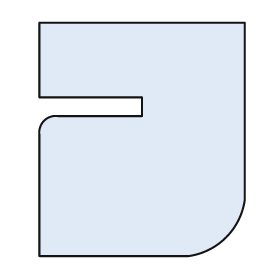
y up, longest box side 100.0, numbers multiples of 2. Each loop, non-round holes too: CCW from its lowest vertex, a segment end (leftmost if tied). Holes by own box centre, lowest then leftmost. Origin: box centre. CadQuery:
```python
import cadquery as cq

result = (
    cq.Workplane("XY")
    .moveTo(-44.0, -50.0)
    .lineTo(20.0, -50.0)
    .threePointArc((36.0, -42.0), (44.0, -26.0))
    .lineTo(44.0, 50.0)
    .lineTo(-44.0, 50.0)
    .lineTo(-44.0, 18.0)
    .lineTo(0.0, 18.0)
    .lineTo(0.0, 10.0)
    .lineTo(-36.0, 10.0)
    .threePointArc((-42.0, 8.0), (-44.0, 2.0))
    .close()
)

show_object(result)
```